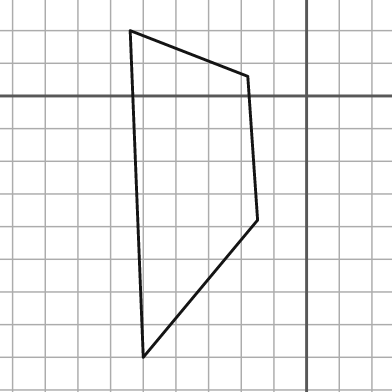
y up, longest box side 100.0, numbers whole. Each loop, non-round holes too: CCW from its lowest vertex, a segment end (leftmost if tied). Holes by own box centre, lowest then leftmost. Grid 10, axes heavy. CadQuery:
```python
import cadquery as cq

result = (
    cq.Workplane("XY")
    .moveTo(-50.0, -80.0)
    .lineTo(-15.0, -38.0)
    .lineTo(-18.0, 6.0)
    .lineTo(-54.0, 20.0)
    .close()
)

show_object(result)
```